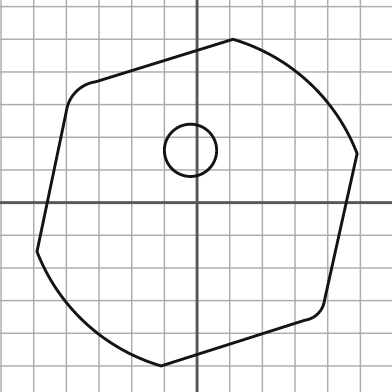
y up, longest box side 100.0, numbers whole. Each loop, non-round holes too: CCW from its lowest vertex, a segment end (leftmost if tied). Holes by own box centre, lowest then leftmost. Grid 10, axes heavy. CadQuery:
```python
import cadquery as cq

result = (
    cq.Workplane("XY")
    .moveTo(-11.0, -50.0)
    .lineTo(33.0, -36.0)
    .threePointArc((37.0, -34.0), (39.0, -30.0))
    .lineTo(49.0, 15.0)
    .threePointArc((34.0, 37.0), (11.0, 50.0))
    .lineTo(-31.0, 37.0)
    .threePointArc((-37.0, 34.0), (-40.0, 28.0))
    .lineTo(-49.0, -15.0)
    .threePointArc((-34.0, -37.0), (-11.0, -50.0))
    .close()
    .moveTo(-2.0, 16.0)
    .circle(8.0)
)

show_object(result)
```